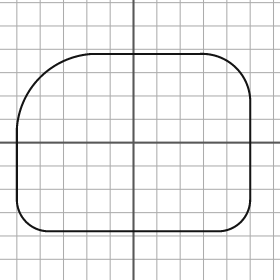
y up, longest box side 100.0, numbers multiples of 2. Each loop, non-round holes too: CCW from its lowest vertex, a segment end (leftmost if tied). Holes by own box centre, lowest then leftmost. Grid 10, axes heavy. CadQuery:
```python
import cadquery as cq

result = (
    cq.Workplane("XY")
    .moveTo(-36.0, -38.0)
    .lineTo(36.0, -38.0)
    .threePointArc((46.0, -34.0), (50.0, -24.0))
    .lineTo(50.0, 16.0)
    .threePointArc((44.0, 32.0), (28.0, 38.0))
    .lineTo(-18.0, 38.0)
    .threePointArc((-40.0, 28.0), (-50.0, 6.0))
    .lineTo(-50.0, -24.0)
    .threePointArc((-46.0, -34.0), (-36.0, -38.0))
    .close()
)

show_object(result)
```